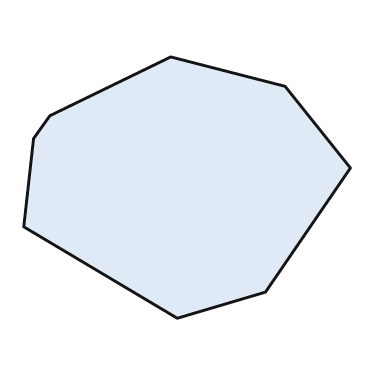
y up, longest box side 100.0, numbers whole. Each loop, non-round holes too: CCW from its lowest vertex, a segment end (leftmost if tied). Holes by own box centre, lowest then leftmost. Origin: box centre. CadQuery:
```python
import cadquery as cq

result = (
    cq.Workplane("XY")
    .moveTo(-3.0, -40.0)
    .lineTo(24.0, -32.0)
    .lineTo(50.0, 6.0)
    .lineTo(30.0, 31.0)
    .lineTo(-5.0, 40.0)
    .lineTo(-42.0, 22.0)
    .lineTo(-47.0, 15.0)
    .lineTo(-50.0, -12.0)
    .close()
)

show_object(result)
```